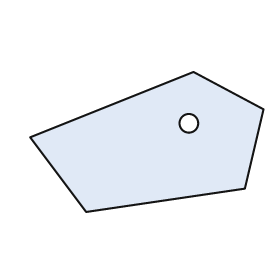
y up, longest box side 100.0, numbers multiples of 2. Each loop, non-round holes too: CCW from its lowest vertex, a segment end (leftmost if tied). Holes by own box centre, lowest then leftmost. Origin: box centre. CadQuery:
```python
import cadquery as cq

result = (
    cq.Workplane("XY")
    .moveTo(-26.0, -30.0)
    .lineTo(42.0, -20.0)
    .lineTo(50.0, 14.0)
    .lineTo(20.0, 30.0)
    .lineTo(-50.0, 2.0)
    .close()
    .moveTo(18.0, 8.0)
    .circle(4.0)
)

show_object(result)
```